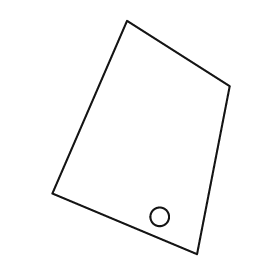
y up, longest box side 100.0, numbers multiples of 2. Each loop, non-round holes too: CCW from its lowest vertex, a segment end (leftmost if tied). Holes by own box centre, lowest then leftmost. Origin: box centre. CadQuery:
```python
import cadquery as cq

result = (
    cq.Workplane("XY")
    .moveTo(24.0, -50.0)
    .lineTo(38.0, 22.0)
    .lineTo(-6.0, 50.0)
    .lineTo(-38.0, -24.0)
    .close()
    .moveTo(8.0, -34.0)
    .circle(4.0)
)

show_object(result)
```